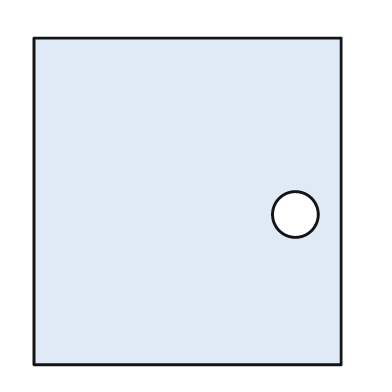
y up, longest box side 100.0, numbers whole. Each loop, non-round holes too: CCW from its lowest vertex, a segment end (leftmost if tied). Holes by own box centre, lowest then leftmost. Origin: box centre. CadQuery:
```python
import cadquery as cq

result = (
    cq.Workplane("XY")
    .moveTo(-47.0, -50.0)
    .lineTo(47.0, -50.0)
    .lineTo(47.0, 50.0)
    .lineTo(-47.0, 50.0)
    .close()
    .moveTo(33.0, -4.0)
    .circle(7.0)
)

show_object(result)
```